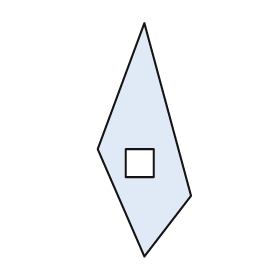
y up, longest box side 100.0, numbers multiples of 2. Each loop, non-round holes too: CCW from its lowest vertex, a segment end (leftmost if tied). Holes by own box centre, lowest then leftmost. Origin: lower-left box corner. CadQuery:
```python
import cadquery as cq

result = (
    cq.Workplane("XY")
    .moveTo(20.0, 0.0)
    .lineTo(40.0, 26.0)
    .lineTo(20.0, 100.0)
    .lineTo(0.0, 46.0)
    .close()
    .moveTo(12.0, 34.0)
    .lineTo(24.0, 34.0)
    .lineTo(24.0, 46.0)
    .lineTo(12.0, 46.0)
    .close()
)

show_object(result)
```